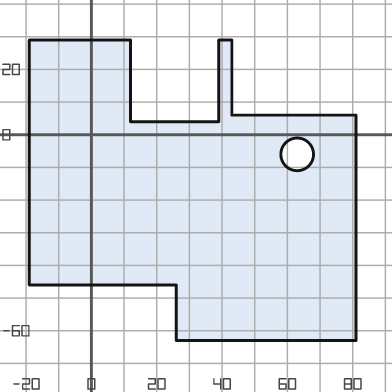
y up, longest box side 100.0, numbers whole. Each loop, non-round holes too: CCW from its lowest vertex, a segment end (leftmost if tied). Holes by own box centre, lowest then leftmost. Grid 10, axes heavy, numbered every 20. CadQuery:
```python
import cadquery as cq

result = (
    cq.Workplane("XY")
    .moveTo(26.0, -63.0)
    .lineTo(81.0, -63.0)
    .lineTo(81.0, 6.0)
    .lineTo(43.0, 6.0)
    .lineTo(43.0, 29.0)
    .lineTo(39.0, 29.0)
    .lineTo(39.0, 4.0)
    .lineTo(12.0, 4.0)
    .lineTo(12.0, 29.0)
    .lineTo(-19.0, 29.0)
    .lineTo(-19.0, -46.0)
    .lineTo(26.0, -46.0)
    .close()
    .moveTo(63.0, -6.0)
    .circle(5.0)
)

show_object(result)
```